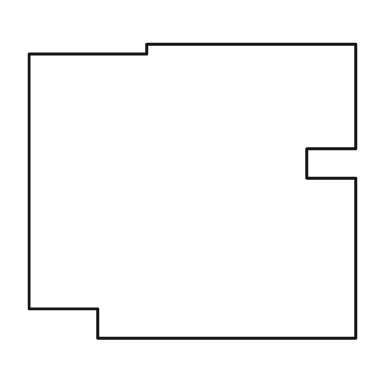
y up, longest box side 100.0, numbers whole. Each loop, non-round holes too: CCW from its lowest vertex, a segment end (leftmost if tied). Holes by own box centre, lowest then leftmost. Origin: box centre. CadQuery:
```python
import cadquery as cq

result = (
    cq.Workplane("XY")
    .moveTo(-29.0, -45.0)
    .lineTo(50.0, -45.0)
    .lineTo(50.0, 4.0)
    .lineTo(35.0, 4.0)
    .lineTo(35.0, 13.0)
    .lineTo(50.0, 13.0)
    .lineTo(50.0, 45.0)
    .lineTo(-14.0, 45.0)
    .lineTo(-14.0, 42.0)
    .lineTo(-50.0, 42.0)
    .lineTo(-50.0, -36.0)
    .lineTo(-29.0, -36.0)
    .close()
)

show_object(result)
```